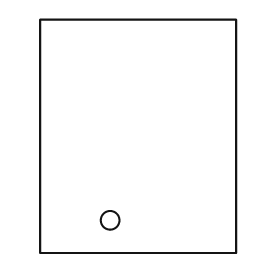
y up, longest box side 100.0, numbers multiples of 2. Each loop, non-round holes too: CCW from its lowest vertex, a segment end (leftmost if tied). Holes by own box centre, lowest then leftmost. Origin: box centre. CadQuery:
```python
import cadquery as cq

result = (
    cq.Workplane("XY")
    .moveTo(-42.0, -50.0)
    .lineTo(42.0, -50.0)
    .lineTo(42.0, 50.0)
    .lineTo(-42.0, 50.0)
    .close()
    .moveTo(-12.0, -36.0)
    .circle(4.0)
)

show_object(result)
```